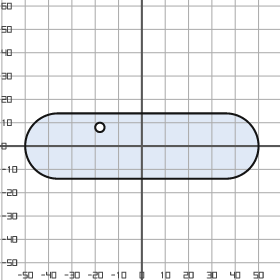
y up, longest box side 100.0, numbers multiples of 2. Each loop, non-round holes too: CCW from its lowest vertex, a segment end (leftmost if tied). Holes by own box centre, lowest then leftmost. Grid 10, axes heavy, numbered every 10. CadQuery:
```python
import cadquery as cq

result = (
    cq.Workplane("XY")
    .moveTo(-36.0, -14.0)
    .lineTo(36.0, -14.0)
    .threePointArc((50.0, 0.0), (36.0, 14.0))
    .lineTo(-36.0, 14.0)
    .threePointArc((-50.0, 0.0), (-36.0, -14.0))
    .close()
    .moveTo(-18.0, 8.0)
    .circle(2.0)
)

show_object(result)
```